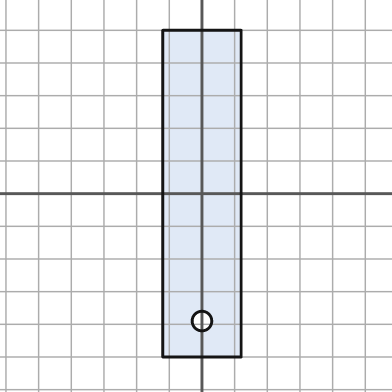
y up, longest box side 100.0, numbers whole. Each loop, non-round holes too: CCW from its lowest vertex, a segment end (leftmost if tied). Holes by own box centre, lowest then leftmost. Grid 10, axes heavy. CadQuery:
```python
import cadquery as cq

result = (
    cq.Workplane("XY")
    .moveTo(-12.0, -50.0)
    .lineTo(12.0, -50.0)
    .lineTo(12.0, 50.0)
    .lineTo(-12.0, 50.0)
    .close()
    .moveTo(0.0, -39.0)
    .circle(3.0)
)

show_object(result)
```